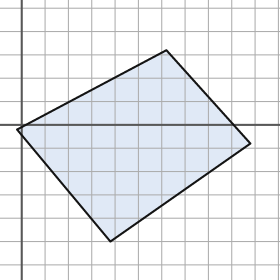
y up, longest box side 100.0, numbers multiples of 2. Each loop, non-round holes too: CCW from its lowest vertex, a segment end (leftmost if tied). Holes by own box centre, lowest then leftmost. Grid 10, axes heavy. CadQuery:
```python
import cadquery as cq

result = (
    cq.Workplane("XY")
    .moveTo(38.0, -50.0)
    .lineTo(98.0, -8.0)
    .lineTo(62.0, 32.0)
    .lineTo(-2.0, -2.0)
    .close()
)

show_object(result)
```